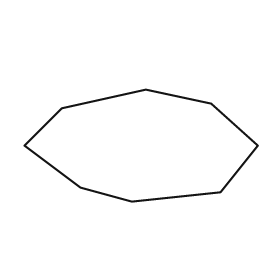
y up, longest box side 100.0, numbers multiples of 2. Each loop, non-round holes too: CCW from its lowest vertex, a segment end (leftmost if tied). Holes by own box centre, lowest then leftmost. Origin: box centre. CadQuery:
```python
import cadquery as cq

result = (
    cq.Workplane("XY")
    .moveTo(-4.0, -24.0)
    .lineTo(34.0, -20.0)
    .lineTo(50.0, 0.0)
    .lineTo(30.0, 18.0)
    .lineTo(2.0, 24.0)
    .lineTo(-34.0, 16.0)
    .lineTo(-50.0, 0.0)
    .lineTo(-26.0, -18.0)
    .close()
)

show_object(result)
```